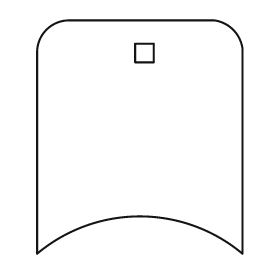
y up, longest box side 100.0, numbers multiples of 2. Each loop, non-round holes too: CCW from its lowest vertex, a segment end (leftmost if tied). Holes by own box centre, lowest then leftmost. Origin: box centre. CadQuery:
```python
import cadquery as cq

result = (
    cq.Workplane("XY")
    .moveTo(-44.0, -50.0)
    .threePointArc((0.0, -34.0), (44.0, -50.0))
    .lineTo(44.0, 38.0)
    .threePointArc((40.0, 46.0), (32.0, 50.0))
    .lineTo(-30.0, 50.0)
    .threePointArc((-40.0, 46.0), (-44.0, 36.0))
    .close()
    .moveTo(-2.0, 32.0)
    .lineTo(6.0, 32.0)
    .lineTo(6.0, 40.0)
    .lineTo(-2.0, 40.0)
    .close()
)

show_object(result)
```